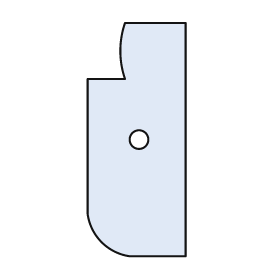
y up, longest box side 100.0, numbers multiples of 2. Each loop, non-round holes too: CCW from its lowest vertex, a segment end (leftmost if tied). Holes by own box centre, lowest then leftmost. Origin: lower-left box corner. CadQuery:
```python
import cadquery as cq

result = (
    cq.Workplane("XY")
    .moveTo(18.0, 0.0)
    .lineTo(42.0, 0.0)
    .lineTo(42.0, 100.0)
    .lineTo(16.0, 100.0)
    .threePointArc((14.0, 88.0), (16.0, 76.0))
    .lineTo(0.0, 76.0)
    .lineTo(0.0, 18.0)
    .threePointArc((6.0, 6.0), (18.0, 0.0))
    .close()
    .moveTo(22.0, 50.0)
    .circle(4.0)
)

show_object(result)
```